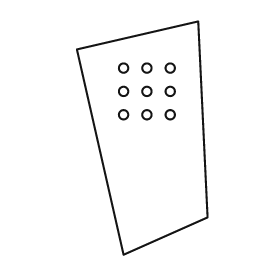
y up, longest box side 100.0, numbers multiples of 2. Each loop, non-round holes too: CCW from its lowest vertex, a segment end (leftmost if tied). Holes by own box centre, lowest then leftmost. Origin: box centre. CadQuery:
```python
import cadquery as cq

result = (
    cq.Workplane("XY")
    .moveTo(-8.0, -50.0)
    .lineTo(28.0, -34.0)
    .lineTo(24.0, 50.0)
    .lineTo(-28.0, 38.0)
    .close()
    .moveTo(-8.0, 10.0)
    .circle(2.0)
    .moveTo(2.0, 10.0)
    .circle(2.0)
    .moveTo(12.0, 10.0)
    .circle(2.0)
    .moveTo(-8.0, 20.0)
    .circle(2.0)
    .moveTo(2.0, 20.0)
    .circle(2.0)
    .moveTo(12.0, 20.0)
    .circle(2.0)
    .moveTo(-8.0, 30.0)
    .circle(2.0)
    .moveTo(2.0, 30.0)
    .circle(2.0)
    .moveTo(12.0, 30.0)
    .circle(2.0)
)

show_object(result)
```